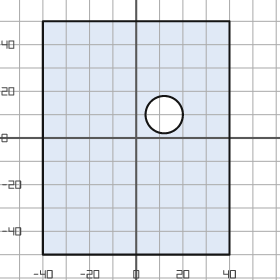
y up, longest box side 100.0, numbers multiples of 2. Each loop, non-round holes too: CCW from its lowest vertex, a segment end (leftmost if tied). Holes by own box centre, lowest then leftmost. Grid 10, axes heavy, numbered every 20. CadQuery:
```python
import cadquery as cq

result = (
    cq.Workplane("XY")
    .moveTo(-40.0, -50.0)
    .lineTo(40.0, -50.0)
    .lineTo(40.0, 50.0)
    .lineTo(-40.0, 50.0)
    .close()
    .moveTo(12.0, 10.0)
    .circle(8.0)
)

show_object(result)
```